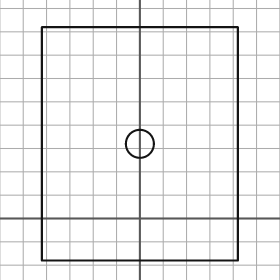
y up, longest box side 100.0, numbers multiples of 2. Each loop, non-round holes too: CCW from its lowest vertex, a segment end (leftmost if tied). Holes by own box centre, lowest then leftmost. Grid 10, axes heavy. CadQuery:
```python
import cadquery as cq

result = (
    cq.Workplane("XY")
    .moveTo(-42.0, -18.0)
    .lineTo(42.0, -18.0)
    .lineTo(42.0, 82.0)
    .lineTo(-42.0, 82.0)
    .close()
    .moveTo(0.0, 32.0)
    .circle(6.0)
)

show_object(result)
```